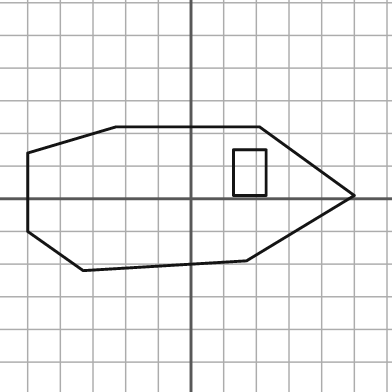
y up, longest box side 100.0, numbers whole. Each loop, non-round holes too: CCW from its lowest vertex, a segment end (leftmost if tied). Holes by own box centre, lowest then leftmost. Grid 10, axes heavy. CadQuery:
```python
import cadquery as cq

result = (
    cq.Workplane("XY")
    .moveTo(-33.0, -22.0)
    .lineTo(17.0, -19.0)
    .lineTo(50.0, 1.0)
    .lineTo(21.0, 22.0)
    .lineTo(-23.0, 22.0)
    .lineTo(-50.0, 14.0)
    .lineTo(-50.0, -10.0)
    .close()
    .moveTo(13.0, 1.0)
    .lineTo(23.0, 1.0)
    .lineTo(23.0, 15.0)
    .lineTo(13.0, 15.0)
    .close()
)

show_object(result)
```